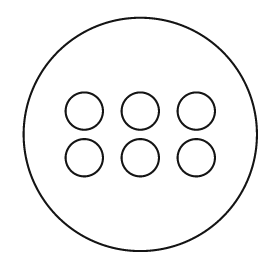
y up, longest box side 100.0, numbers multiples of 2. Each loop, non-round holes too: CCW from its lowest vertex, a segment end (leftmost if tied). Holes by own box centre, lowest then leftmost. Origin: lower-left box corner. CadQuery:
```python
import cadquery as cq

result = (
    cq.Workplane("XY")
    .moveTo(50.0, 50.0)
    .circle(50.0)
    .moveTo(26.0, 40.0)
    .circle(8.0)
    .moveTo(50.0, 40.0)
    .circle(8.0)
    .moveTo(74.0, 40.0)
    .circle(8.0)
    .moveTo(26.0, 60.0)
    .circle(8.0)
    .moveTo(50.0, 60.0)
    .circle(8.0)
    .moveTo(74.0, 60.0)
    .circle(8.0)
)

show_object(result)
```